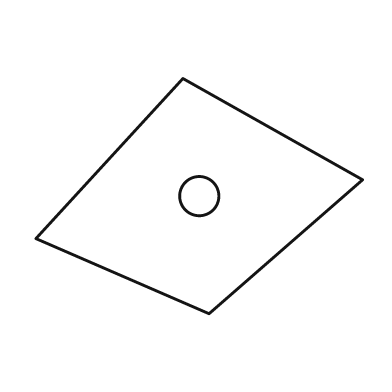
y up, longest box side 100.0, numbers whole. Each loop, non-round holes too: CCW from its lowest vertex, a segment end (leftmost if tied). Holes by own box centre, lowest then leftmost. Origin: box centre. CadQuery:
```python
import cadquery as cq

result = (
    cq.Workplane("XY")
    .moveTo(3.0, -36.0)
    .lineTo(50.0, 5.0)
    .lineTo(-5.0, 36.0)
    .lineTo(-50.0, -13.0)
    .close()
    .moveTo(0.0, 0.0)
    .circle(6.0)
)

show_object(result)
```